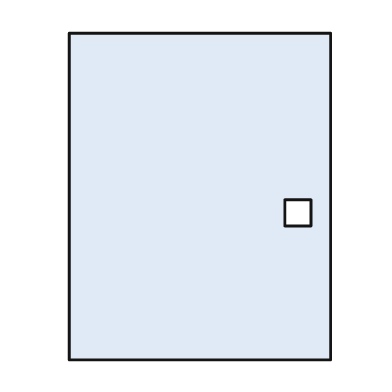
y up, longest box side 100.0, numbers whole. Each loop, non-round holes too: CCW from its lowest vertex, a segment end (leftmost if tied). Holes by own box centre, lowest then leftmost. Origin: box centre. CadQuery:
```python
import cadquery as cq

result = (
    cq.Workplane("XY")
    .moveTo(-40.0, -50.0)
    .lineTo(40.0, -50.0)
    .lineTo(40.0, 50.0)
    .lineTo(-40.0, 50.0)
    .close()
    .moveTo(26.0, -9.0)
    .lineTo(34.0, -9.0)
    .lineTo(34.0, -1.0)
    .lineTo(26.0, -1.0)
    .close()
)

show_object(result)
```